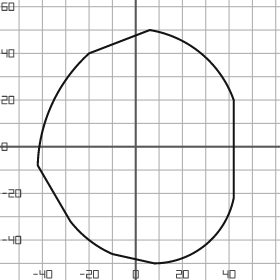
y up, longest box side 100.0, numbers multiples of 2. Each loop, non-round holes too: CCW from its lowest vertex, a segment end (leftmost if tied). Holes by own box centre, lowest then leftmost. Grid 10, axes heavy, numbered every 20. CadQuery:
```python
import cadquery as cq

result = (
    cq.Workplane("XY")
    .moveTo(8.0, -50.0)
    .threePointArc((30.0, -42.0), (42.0, -22.0))
    .lineTo(42.0, 20.0)
    .threePointArc((28.0, 40.0), (6.0, 50.0))
    .lineTo(-20.0, 40.0)
    .threePointArc((-36.0, 18.0), (-42.0, -8.0))
    .lineTo(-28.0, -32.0)
    .threePointArc((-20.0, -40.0), (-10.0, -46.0))
    .close()
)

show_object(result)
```